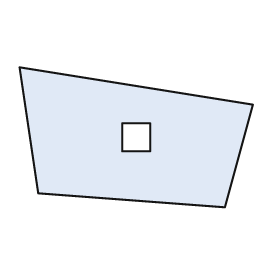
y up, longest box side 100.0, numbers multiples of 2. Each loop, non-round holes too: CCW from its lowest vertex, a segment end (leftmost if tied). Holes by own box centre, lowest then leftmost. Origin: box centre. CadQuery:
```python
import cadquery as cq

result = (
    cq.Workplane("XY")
    .moveTo(38.0, -30.0)
    .lineTo(50.0, 14.0)
    .lineTo(-50.0, 30.0)
    .lineTo(-42.0, -24.0)
    .close()
    .moveTo(-6.0, -6.0)
    .lineTo(6.0, -6.0)
    .lineTo(6.0, 6.0)
    .lineTo(-6.0, 6.0)
    .close()
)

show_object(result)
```